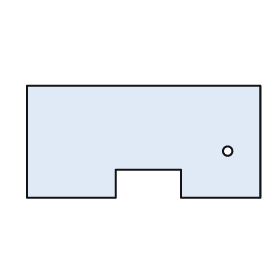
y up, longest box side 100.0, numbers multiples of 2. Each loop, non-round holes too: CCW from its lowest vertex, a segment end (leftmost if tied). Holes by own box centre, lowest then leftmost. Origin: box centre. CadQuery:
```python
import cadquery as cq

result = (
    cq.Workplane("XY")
    .moveTo(-50.0, -24.0)
    .lineTo(-12.0, -24.0)
    .lineTo(-12.0, -12.0)
    .lineTo(16.0, -12.0)
    .lineTo(16.0, -24.0)
    .lineTo(50.0, -24.0)
    .lineTo(50.0, 24.0)
    .lineTo(-50.0, 24.0)
    .close()
    .moveTo(36.0, -4.0)
    .circle(2.0)
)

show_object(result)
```